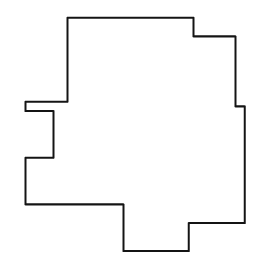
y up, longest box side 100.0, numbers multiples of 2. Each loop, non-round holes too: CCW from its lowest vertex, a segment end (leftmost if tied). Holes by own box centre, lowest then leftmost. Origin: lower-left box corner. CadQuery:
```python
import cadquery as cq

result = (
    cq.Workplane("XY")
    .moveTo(42.0, 0.0)
    .lineTo(70.0, 0.0)
    .lineTo(70.0, 12.0)
    .lineTo(94.0, 12.0)
    .lineTo(94.0, 62.0)
    .lineTo(90.0, 62.0)
    .lineTo(90.0, 92.0)
    .lineTo(72.0, 92.0)
    .lineTo(72.0, 100.0)
    .lineTo(18.0, 100.0)
    .lineTo(18.0, 64.0)
    .lineTo(0.0, 64.0)
    .lineTo(0.0, 60.0)
    .lineTo(12.0, 60.0)
    .lineTo(12.0, 40.0)
    .lineTo(0.0, 40.0)
    .lineTo(0.0, 20.0)
    .lineTo(42.0, 20.0)
    .close()
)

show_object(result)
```